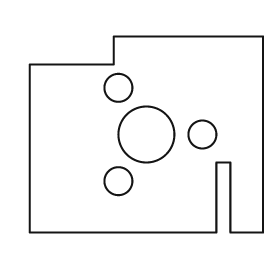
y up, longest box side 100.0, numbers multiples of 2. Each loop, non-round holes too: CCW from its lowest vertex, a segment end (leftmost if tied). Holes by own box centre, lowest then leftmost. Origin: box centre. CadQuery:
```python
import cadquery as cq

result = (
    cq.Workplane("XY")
    .moveTo(-50.0, -42.0)
    .lineTo(30.0, -42.0)
    .lineTo(30.0, -12.0)
    .lineTo(36.0, -12.0)
    .lineTo(36.0, -42.0)
    .lineTo(50.0, -42.0)
    .lineTo(50.0, 42.0)
    .lineTo(-14.0, 42.0)
    .lineTo(-14.0, 30.0)
    .lineTo(-50.0, 30.0)
    .close()
    .moveTo(-12.0, -20.0)
    .circle(6.0)
    .moveTo(0.0, 0.0)
    .circle(12.0)
    .moveTo(24.0, 0.0)
    .circle(6.0)
    .moveTo(-12.0, 20.0)
    .circle(6.0)
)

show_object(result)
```